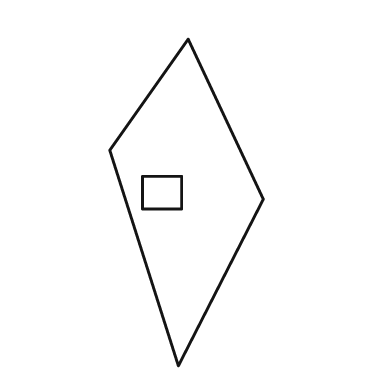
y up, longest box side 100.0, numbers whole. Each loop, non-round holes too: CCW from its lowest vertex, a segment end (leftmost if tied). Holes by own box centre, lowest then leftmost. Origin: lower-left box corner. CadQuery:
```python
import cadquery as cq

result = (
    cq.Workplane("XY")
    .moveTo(21.0, 0.0)
    .lineTo(47.0, 51.0)
    .lineTo(24.0, 100.0)
    .lineTo(0.0, 66.0)
    .close()
    .moveTo(10.0, 48.0)
    .lineTo(22.0, 48.0)
    .lineTo(22.0, 58.0)
    .lineTo(10.0, 58.0)
    .close()
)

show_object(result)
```